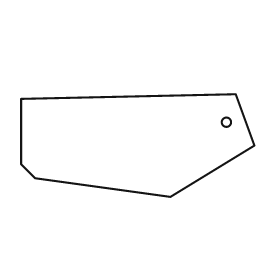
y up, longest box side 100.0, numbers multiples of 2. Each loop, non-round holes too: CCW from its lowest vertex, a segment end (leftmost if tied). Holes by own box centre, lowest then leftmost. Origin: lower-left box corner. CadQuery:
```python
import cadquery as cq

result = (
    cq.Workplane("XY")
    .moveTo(64.0, 0.0)
    .lineTo(100.0, 22.0)
    .lineTo(92.0, 44.0)
    .lineTo(0.0, 42.0)
    .lineTo(0.0, 14.0)
    .lineTo(6.0, 8.0)
    .close()
    .moveTo(88.0, 32.0)
    .circle(2.0)
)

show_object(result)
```